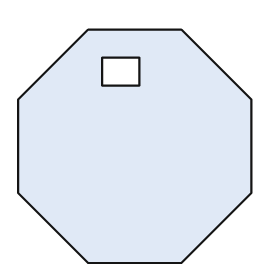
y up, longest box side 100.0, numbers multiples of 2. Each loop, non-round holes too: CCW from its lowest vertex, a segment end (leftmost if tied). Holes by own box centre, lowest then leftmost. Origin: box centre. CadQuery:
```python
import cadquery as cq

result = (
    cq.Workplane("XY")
    .moveTo(-20.0, -50.0)
    .lineTo(20.0, -50.0)
    .lineTo(50.0, -20.0)
    .lineTo(50.0, 20.0)
    .lineTo(20.0, 50.0)
    .lineTo(-20.0, 50.0)
    .lineTo(-50.0, 20.0)
    .lineTo(-50.0, -20.0)
    .close()
    .moveTo(-14.0, 26.0)
    .lineTo(2.0, 26.0)
    .lineTo(2.0, 38.0)
    .lineTo(-14.0, 38.0)
    .close()
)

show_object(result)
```